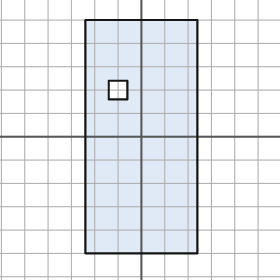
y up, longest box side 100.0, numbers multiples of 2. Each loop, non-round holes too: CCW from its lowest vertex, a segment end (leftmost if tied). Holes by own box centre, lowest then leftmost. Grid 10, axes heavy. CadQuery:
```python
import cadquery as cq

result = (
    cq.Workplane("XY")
    .moveTo(-24.0, -50.0)
    .lineTo(24.0, -50.0)
    .lineTo(24.0, 50.0)
    .lineTo(-24.0, 50.0)
    .close()
    .moveTo(-14.0, 16.0)
    .lineTo(-6.0, 16.0)
    .lineTo(-6.0, 24.0)
    .lineTo(-14.0, 24.0)
    .close()
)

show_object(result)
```